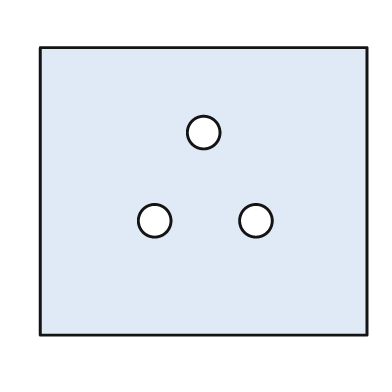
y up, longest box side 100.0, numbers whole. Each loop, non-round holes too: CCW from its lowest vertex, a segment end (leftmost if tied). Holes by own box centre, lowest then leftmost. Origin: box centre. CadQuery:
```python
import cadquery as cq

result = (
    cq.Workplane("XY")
    .moveTo(-50.0, -44.0)
    .lineTo(50.0, -44.0)
    .lineTo(50.0, 44.0)
    .lineTo(-50.0, 44.0)
    .close()
    .moveTo(-15.0, -9.0)
    .circle(5.0)
    .moveTo(16.0, -9.0)
    .circle(5.0)
    .moveTo(0.0, 18.0)
    .circle(5.0)
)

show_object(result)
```